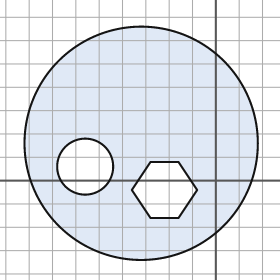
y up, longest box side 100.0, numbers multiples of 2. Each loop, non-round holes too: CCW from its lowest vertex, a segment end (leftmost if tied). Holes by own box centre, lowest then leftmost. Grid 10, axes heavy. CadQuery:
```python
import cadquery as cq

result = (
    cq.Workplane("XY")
    .moveTo(-32.0, 16.0)
    .circle(50.0)
    .moveTo(-28.0, -16.0)
    .lineTo(-16.0, -16.0)
    .lineTo(-8.0, -4.0)
    .lineTo(-16.0, 8.0)
    .lineTo(-28.0, 8.0)
    .lineTo(-36.0, -4.0)
    .close()
    .moveTo(-56.0, 6.0)
    .circle(12.0)
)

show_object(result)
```